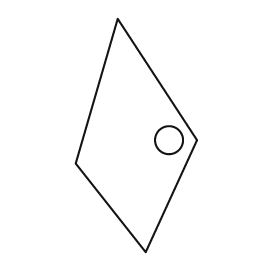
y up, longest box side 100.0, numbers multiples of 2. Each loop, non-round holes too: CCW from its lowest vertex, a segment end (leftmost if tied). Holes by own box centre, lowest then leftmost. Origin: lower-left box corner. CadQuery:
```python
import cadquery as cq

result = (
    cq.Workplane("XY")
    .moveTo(30.0, 0.0)
    .lineTo(52.0, 48.0)
    .lineTo(18.0, 100.0)
    .lineTo(0.0, 38.0)
    .close()
    .moveTo(40.0, 48.0)
    .circle(6.0)
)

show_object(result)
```